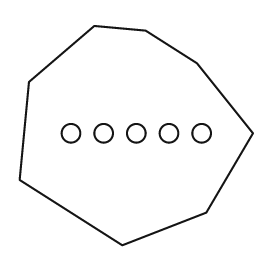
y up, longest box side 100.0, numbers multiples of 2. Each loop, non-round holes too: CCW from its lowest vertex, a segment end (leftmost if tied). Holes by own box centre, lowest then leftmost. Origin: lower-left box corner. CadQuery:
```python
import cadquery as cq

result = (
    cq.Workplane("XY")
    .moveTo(44.0, 0.0)
    .lineTo(80.0, 14.0)
    .lineTo(100.0, 48.0)
    .lineTo(76.0, 78.0)
    .lineTo(54.0, 92.0)
    .lineTo(32.0, 94.0)
    .lineTo(4.0, 70.0)
    .lineTo(0.0, 28.0)
    .close()
    .moveTo(22.0, 48.0)
    .circle(4.0)
    .moveTo(36.0, 48.0)
    .circle(4.0)
    .moveTo(50.0, 48.0)
    .circle(4.0)
    .moveTo(64.0, 48.0)
    .circle(4.0)
    .moveTo(78.0, 48.0)
    .circle(4.0)
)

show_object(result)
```